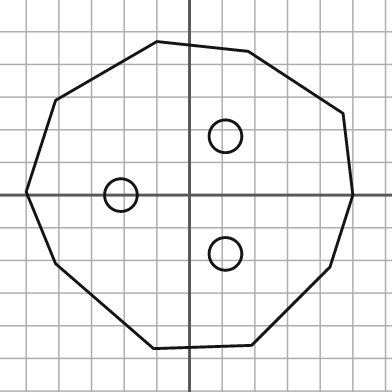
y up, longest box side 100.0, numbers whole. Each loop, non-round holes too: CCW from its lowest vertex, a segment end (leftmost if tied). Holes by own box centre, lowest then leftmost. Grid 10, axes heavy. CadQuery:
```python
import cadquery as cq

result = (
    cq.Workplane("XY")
    .moveTo(-11.0, -47.0)
    .lineTo(19.0, -46.0)
    .lineTo(43.0, -22.0)
    .lineTo(50.0, 0.0)
    .lineTo(47.0, 25.0)
    .lineTo(18.0, 44.0)
    .lineTo(-10.0, 47.0)
    .lineTo(-41.0, 29.0)
    .lineTo(-50.0, 1.0)
    .lineTo(-41.0, -21.0)
    .close()
    .moveTo(11.0, -18.0)
    .circle(5.0)
    .moveTo(-21.0, 0.0)
    .circle(5.0)
    .moveTo(11.0, 18.0)
    .circle(5.0)
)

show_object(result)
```